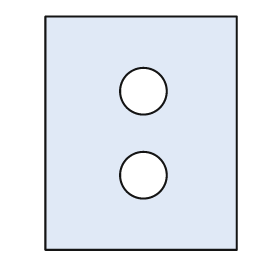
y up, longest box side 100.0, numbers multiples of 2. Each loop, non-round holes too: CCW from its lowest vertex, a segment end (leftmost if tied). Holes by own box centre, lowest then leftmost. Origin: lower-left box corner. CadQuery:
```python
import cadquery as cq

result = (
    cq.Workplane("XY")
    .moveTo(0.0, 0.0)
    .lineTo(82.0, 0.0)
    .lineTo(82.0, 100.0)
    .lineTo(0.0, 100.0)
    .close()
    .moveTo(42.0, 32.0)
    .circle(10.0)
    .moveTo(42.0, 68.0)
    .circle(10.0)
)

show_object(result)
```